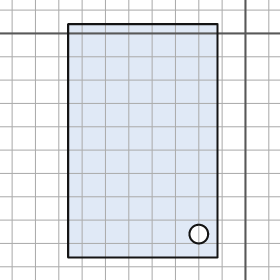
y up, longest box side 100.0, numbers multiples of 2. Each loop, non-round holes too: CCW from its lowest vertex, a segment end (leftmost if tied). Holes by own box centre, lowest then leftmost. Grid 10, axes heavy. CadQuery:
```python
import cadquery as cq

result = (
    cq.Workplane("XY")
    .moveTo(-76.0, -96.0)
    .lineTo(-12.0, -96.0)
    .lineTo(-12.0, 4.0)
    .lineTo(-76.0, 4.0)
    .close()
    .moveTo(-20.0, -86.0)
    .circle(4.0)
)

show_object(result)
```